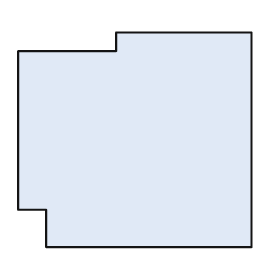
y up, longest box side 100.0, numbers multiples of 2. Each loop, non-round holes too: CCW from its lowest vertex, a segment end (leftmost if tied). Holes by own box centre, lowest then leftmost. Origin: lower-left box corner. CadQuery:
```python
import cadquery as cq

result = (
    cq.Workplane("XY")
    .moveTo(12.0, 0.0)
    .lineTo(100.0, 0.0)
    .lineTo(100.0, 92.0)
    .lineTo(42.0, 92.0)
    .lineTo(42.0, 84.0)
    .lineTo(0.0, 84.0)
    .lineTo(0.0, 16.0)
    .lineTo(12.0, 16.0)
    .close()
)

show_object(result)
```